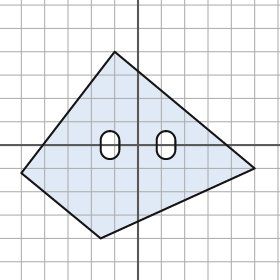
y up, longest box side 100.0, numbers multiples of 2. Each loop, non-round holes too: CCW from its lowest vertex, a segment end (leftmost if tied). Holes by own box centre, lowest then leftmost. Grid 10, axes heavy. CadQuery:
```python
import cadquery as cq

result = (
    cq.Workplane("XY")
    .moveTo(-16.0, -40.0)
    .lineTo(50.0, -10.0)
    .lineTo(-10.0, 40.0)
    .lineTo(-50.0, -12.0)
    .close()
    .moveTo(-16.0, -2.0)
    .threePointArc((-12.0, -6.0), (-8.0, -2.0))
    .lineTo(-8.0, 2.0)
    .threePointArc((-12.0, 6.0), (-16.0, 2.0))
    .close()
    .moveTo(8.0, -2.0)
    .threePointArc((12.0, -6.0), (16.0, -2.0))
    .lineTo(16.0, 2.0)
    .threePointArc((12.0, 6.0), (8.0, 2.0))
    .close()
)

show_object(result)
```